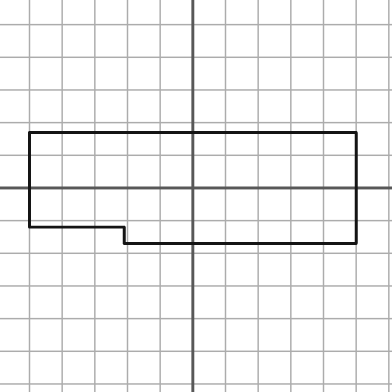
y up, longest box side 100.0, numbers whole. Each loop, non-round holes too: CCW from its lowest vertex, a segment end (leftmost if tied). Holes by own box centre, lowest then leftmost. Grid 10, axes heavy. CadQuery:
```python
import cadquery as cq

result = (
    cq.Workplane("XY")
    .moveTo(-21.0, -17.0)
    .lineTo(50.0, -17.0)
    .lineTo(50.0, 17.0)
    .lineTo(-50.0, 17.0)
    .lineTo(-50.0, -12.0)
    .lineTo(-21.0, -12.0)
    .close()
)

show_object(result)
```